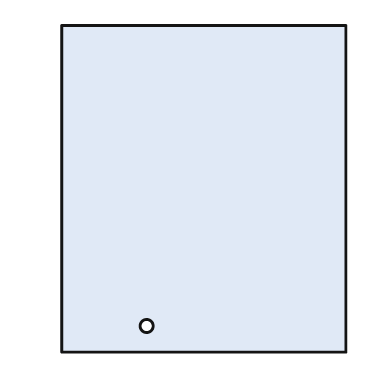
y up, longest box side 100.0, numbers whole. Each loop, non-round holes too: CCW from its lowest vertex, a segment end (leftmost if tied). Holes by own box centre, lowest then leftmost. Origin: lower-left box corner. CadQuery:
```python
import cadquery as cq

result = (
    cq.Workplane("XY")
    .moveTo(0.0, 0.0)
    .lineTo(87.0, 0.0)
    .lineTo(87.0, 100.0)
    .lineTo(0.0, 100.0)
    .close()
    .moveTo(26.0, 8.0)
    .circle(2.0)
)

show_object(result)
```